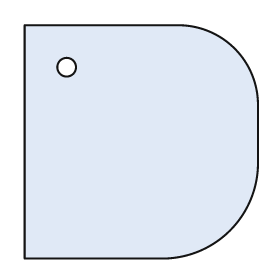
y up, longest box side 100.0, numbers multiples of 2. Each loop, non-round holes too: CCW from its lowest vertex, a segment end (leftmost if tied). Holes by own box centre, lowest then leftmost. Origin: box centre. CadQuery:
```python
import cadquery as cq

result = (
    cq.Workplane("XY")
    .moveTo(-50.0, -50.0)
    .lineTo(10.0, -50.0)
    .threePointArc((38.0, -38.0), (50.0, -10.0))
    .lineTo(50.0, 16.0)
    .threePointArc((40.0, 40.0), (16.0, 50.0))
    .lineTo(-50.0, 50.0)
    .close()
    .moveTo(-32.0, 32.0)
    .circle(4.0)
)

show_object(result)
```